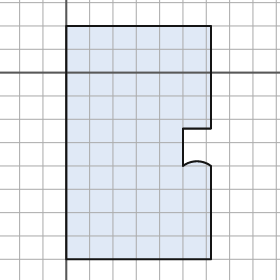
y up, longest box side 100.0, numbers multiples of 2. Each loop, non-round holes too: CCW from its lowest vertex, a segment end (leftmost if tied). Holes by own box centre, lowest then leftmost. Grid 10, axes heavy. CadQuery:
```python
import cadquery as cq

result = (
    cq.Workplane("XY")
    .moveTo(0.0, -80.0)
    .lineTo(62.0, -80.0)
    .lineTo(62.0, -40.0)
    .threePointArc((56.0, -38.0), (50.0, -40.0))
    .lineTo(50.0, -24.0)
    .lineTo(62.0, -24.0)
    .lineTo(62.0, 20.0)
    .lineTo(0.0, 20.0)
    .close()
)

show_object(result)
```